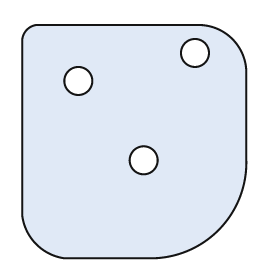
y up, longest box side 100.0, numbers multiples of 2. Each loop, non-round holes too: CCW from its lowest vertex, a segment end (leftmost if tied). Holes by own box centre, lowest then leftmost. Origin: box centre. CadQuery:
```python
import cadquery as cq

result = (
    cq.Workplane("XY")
    .moveTo(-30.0, -50.0)
    .lineTo(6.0, -50.0)
    .threePointArc((36.0, -38.0), (48.0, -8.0))
    .lineTo(48.0, 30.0)
    .threePointArc((42.0, 44.0), (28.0, 50.0))
    .lineTo(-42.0, 50.0)
    .threePointArc((-46.0, 48.0), (-48.0, 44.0))
    .lineTo(-48.0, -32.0)
    .threePointArc((-42.0, -44.0), (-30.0, -50.0))
    .close()
    .moveTo(4.0, -8.0)
    .circle(6.0)
    .moveTo(-24.0, 26.0)
    .circle(6.0)
    .moveTo(26.0, 38.0)
    .circle(6.0)
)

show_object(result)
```